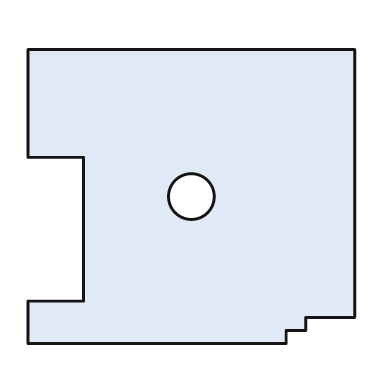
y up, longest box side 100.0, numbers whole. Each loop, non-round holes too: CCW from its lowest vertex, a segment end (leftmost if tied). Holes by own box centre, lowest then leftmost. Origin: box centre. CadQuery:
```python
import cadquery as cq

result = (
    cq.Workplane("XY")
    .moveTo(-50.0, -45.0)
    .lineTo(29.0, -45.0)
    .lineTo(29.0, -41.0)
    .lineTo(35.0, -41.0)
    .lineTo(35.0, -37.0)
    .lineTo(50.0, -37.0)
    .lineTo(50.0, 45.0)
    .lineTo(-50.0, 45.0)
    .lineTo(-50.0, 12.0)
    .lineTo(-33.0, 12.0)
    .lineTo(-33.0, -32.0)
    .lineTo(-50.0, -32.0)
    .close()
    .moveTo(0.0, 0.0)
    .circle(7.0)
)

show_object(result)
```